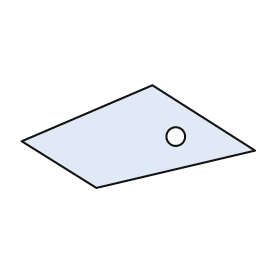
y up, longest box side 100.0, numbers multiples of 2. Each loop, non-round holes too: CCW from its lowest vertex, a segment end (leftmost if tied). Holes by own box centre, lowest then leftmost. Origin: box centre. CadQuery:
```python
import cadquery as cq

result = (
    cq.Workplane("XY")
    .moveTo(-18.0, -22.0)
    .lineTo(50.0, -6.0)
    .lineTo(6.0, 22.0)
    .lineTo(-50.0, -2.0)
    .close()
    .moveTo(16.0, 0.0)
    .circle(4.0)
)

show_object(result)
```